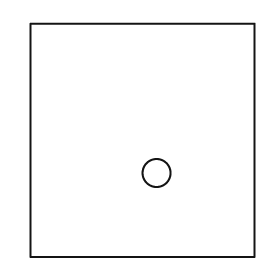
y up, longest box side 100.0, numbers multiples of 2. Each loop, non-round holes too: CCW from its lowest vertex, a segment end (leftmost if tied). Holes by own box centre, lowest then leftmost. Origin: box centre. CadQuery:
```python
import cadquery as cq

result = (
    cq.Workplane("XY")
    .moveTo(-48.0, -50.0)
    .lineTo(48.0, -50.0)
    .lineTo(48.0, 50.0)
    .lineTo(-48.0, 50.0)
    .close()
    .moveTo(6.0, -14.0)
    .circle(6.0)
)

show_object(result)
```